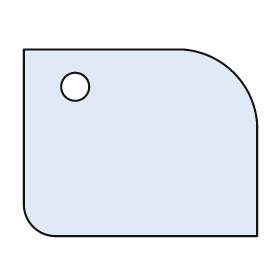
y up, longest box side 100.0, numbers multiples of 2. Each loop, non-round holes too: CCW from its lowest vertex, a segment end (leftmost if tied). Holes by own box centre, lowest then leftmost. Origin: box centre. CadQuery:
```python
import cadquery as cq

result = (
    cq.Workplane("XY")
    .moveTo(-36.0, -40.0)
    .lineTo(50.0, -40.0)
    .lineTo(50.0, 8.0)
    .threePointArc((40.0, 30.0), (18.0, 40.0))
    .lineTo(-50.0, 40.0)
    .lineTo(-50.0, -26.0)
    .threePointArc((-46.0, -36.0), (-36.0, -40.0))
    .close()
    .moveTo(-28.0, 24.0)
    .circle(6.0)
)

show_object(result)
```